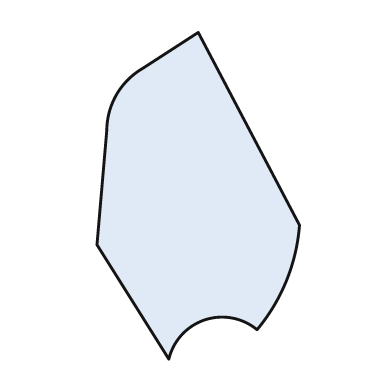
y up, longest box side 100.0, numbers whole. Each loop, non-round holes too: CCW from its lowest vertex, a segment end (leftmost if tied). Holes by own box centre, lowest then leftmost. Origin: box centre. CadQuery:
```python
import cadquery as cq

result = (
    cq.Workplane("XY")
    .moveTo(-9.0, -50.0)
    .threePointArc((2.0, -38.0), (18.0, -41.0))
    .threePointArc((27.0, -26.0), (31.0, -9.0))
    .lineTo(0.0, 50.0)
    .lineTo(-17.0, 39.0)
    .threePointArc((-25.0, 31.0), (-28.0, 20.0))
    .lineTo(-31.0, -15.0)
    .close()
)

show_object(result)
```